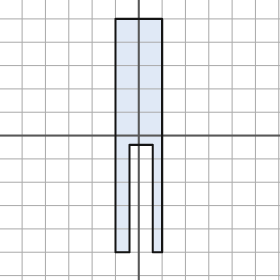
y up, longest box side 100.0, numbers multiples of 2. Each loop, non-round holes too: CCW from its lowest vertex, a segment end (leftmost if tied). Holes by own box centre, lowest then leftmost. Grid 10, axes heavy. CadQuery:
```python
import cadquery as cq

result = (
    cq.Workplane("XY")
    .moveTo(-10.0, -50.0)
    .lineTo(-4.0, -50.0)
    .lineTo(-4.0, -4.0)
    .lineTo(6.0, -4.0)
    .lineTo(6.0, -50.0)
    .lineTo(10.0, -50.0)
    .lineTo(10.0, 50.0)
    .lineTo(-10.0, 50.0)
    .close()
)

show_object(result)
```